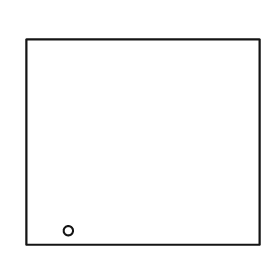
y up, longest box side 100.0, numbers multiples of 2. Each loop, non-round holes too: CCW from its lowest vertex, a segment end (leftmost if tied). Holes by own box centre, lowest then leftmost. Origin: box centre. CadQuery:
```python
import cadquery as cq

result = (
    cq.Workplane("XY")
    .moveTo(-50.0, -44.0)
    .lineTo(50.0, -44.0)
    .lineTo(50.0, 44.0)
    .lineTo(-50.0, 44.0)
    .close()
    .moveTo(-32.0, -38.0)
    .circle(2.0)
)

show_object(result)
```